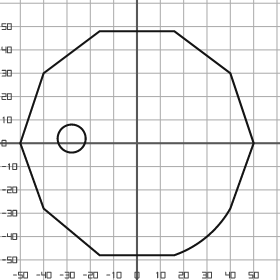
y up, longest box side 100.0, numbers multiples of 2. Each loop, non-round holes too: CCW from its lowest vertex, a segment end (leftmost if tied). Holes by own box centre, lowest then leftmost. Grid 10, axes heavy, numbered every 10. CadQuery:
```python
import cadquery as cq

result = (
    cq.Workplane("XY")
    .moveTo(-16.0, -48.0)
    .lineTo(16.0, -48.0)
    .threePointArc((30.0, -40.0), (40.0, -28.0))
    .lineTo(50.0, 0.0)
    .lineTo(40.0, 30.0)
    .lineTo(16.0, 48.0)
    .lineTo(-16.0, 48.0)
    .lineTo(-40.0, 30.0)
    .lineTo(-50.0, 0.0)
    .lineTo(-40.0, -28.0)
    .close()
    .moveTo(-28.0, 2.0)
    .circle(6.0)
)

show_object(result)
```